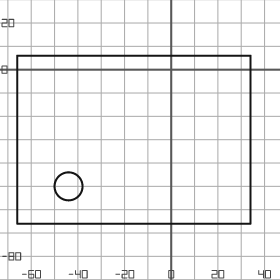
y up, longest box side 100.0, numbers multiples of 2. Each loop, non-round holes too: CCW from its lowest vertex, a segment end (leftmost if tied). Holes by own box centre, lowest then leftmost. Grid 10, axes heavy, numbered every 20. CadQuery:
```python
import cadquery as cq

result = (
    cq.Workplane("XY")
    .moveTo(-66.0, -66.0)
    .lineTo(34.0, -66.0)
    .lineTo(34.0, 6.0)
    .lineTo(-66.0, 6.0)
    .close()
    .moveTo(-44.0, -50.0)
    .circle(6.0)
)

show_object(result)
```